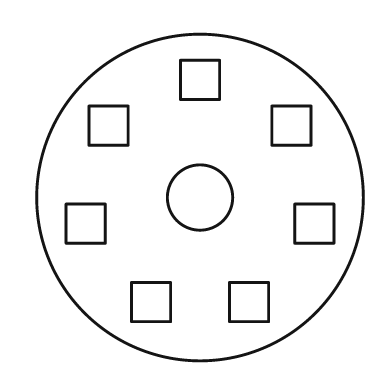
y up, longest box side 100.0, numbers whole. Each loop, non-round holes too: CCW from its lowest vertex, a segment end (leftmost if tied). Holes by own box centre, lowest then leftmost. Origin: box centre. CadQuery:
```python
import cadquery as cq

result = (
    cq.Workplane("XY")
    .moveTo(0.0, 0.0)
    .circle(50.0)
    .moveTo(-21.0, -38.0)
    .lineTo(-9.0, -38.0)
    .lineTo(-9.0, -26.0)
    .lineTo(-21.0, -26.0)
    .close()
    .moveTo(9.0, -38.0)
    .lineTo(21.0, -38.0)
    .lineTo(21.0, -26.0)
    .lineTo(9.0, -26.0)
    .close()
    .moveTo(-41.0, -14.0)
    .lineTo(-29.0, -14.0)
    .lineTo(-29.0, -2.0)
    .lineTo(-41.0, -2.0)
    .close()
    .moveTo(29.0, -14.0)
    .lineTo(41.0, -14.0)
    .lineTo(41.0, -2.0)
    .lineTo(29.0, -2.0)
    .close()
    .moveTo(0.0, 0.0)
    .circle(10.0)
    .moveTo(-34.0, 16.0)
    .lineTo(-22.0, 16.0)
    .lineTo(-22.0, 28.0)
    .lineTo(-34.0, 28.0)
    .close()
    .moveTo(22.0, 16.0)
    .lineTo(34.0, 16.0)
    .lineTo(34.0, 28.0)
    .lineTo(22.0, 28.0)
    .close()
    .moveTo(-6.0, 30.0)
    .lineTo(6.0, 30.0)
    .lineTo(6.0, 42.0)
    .lineTo(-6.0, 42.0)
    .close()
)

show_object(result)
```